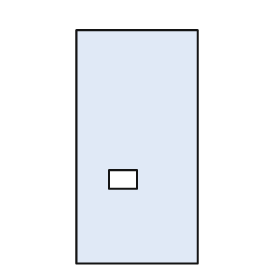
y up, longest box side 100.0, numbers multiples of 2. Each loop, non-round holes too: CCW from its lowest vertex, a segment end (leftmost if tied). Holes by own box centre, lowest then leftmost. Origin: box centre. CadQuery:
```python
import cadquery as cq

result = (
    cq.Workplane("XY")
    .moveTo(-26.0, -50.0)
    .lineTo(26.0, -50.0)
    .lineTo(26.0, 50.0)
    .lineTo(-26.0, 50.0)
    .close()
    .moveTo(-12.0, -18.0)
    .lineTo(0.0, -18.0)
    .lineTo(0.0, -10.0)
    .lineTo(-12.0, -10.0)
    .close()
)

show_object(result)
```